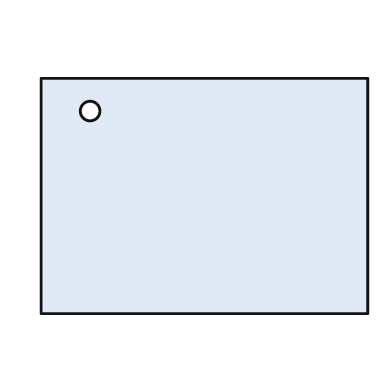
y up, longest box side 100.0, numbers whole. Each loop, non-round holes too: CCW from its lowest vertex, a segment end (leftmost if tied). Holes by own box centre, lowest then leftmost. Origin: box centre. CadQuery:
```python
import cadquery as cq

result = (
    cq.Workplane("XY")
    .moveTo(-50.0, -36.0)
    .lineTo(50.0, -36.0)
    .lineTo(50.0, 36.0)
    .lineTo(-50.0, 36.0)
    .close()
    .moveTo(-35.0, 26.0)
    .circle(3.0)
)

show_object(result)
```